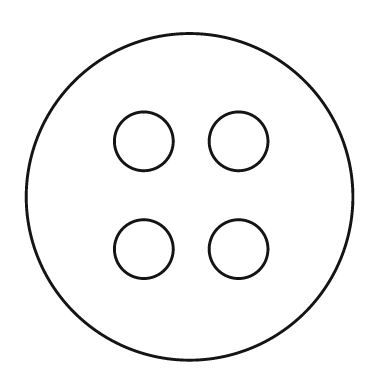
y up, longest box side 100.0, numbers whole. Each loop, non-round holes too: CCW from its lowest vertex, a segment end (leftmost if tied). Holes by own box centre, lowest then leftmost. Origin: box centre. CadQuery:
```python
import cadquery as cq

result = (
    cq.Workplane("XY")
    .moveTo(0.0, 0.0)
    .circle(50.0)
    .moveTo(-14.0, -16.0)
    .circle(9.0)
    .moveTo(15.0, -16.0)
    .circle(9.0)
    .moveTo(-14.0, 17.0)
    .circle(9.0)
    .moveTo(15.0, 17.0)
    .circle(9.0)
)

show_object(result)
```